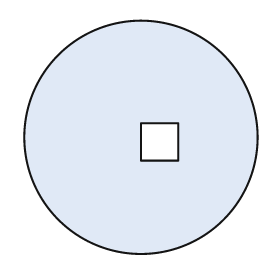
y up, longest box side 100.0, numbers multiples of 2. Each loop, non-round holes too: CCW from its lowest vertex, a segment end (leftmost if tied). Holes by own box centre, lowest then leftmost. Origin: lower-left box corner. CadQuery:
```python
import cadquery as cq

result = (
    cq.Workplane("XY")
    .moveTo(50.0, 50.0)
    .circle(50.0)
    .moveTo(50.0, 40.0)
    .lineTo(66.0, 40.0)
    .lineTo(66.0, 56.0)
    .lineTo(50.0, 56.0)
    .close()
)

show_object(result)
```